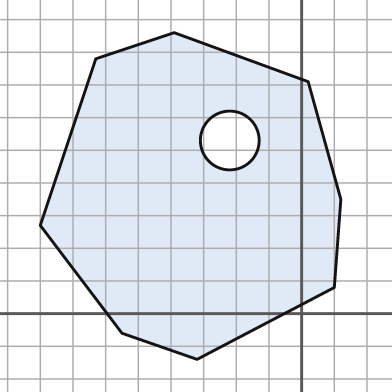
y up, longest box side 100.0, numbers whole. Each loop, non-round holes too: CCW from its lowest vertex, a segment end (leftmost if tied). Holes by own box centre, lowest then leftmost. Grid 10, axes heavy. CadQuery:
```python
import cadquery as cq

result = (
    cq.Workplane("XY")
    .moveTo(-32.0, -14.0)
    .lineTo(10.0, 8.0)
    .lineTo(12.0, 35.0)
    .lineTo(2.0, 71.0)
    .lineTo(-39.0, 86.0)
    .lineTo(-63.0, 78.0)
    .lineTo(-80.0, 27.0)
    .lineTo(-55.0, -6.0)
    .close()
    .moveTo(-22.0, 53.0)
    .circle(9.0)
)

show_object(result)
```